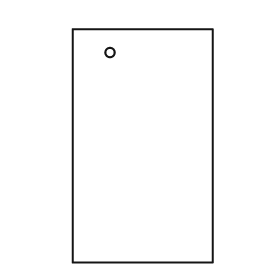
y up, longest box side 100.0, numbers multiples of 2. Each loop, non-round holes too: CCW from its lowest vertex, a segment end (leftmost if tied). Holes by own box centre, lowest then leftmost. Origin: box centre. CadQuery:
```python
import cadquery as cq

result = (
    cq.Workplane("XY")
    .moveTo(-30.0, -50.0)
    .lineTo(30.0, -50.0)
    .lineTo(30.0, 50.0)
    .lineTo(-30.0, 50.0)
    .close()
    .moveTo(-14.0, 40.0)
    .circle(2.0)
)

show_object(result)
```